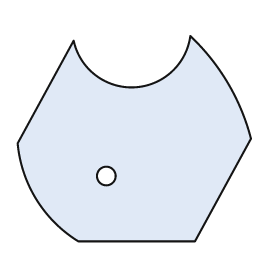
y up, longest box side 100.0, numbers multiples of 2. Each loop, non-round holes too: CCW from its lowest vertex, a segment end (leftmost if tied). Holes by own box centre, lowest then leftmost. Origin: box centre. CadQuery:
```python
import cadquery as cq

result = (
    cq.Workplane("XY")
    .moveTo(-24.0, -44.0)
    .lineTo(26.0, -44.0)
    .lineTo(50.0, 0.0)
    .threePointArc((40.0, 24.0), (24.0, 44.0))
    .threePointArc((0.0, 22.0), (-26.0, 42.0))
    .lineTo(-50.0, -2.0)
    .threePointArc((-42.0, -26.0), (-24.0, -44.0))
    .close()
    .moveTo(-12.0, -16.0)
    .circle(4.0)
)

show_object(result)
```